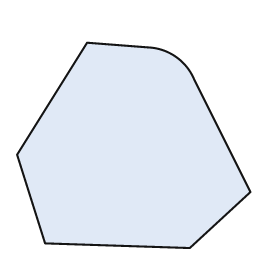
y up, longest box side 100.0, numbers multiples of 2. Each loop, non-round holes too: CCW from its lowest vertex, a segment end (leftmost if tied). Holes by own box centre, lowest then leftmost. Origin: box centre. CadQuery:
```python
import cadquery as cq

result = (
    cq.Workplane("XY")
    .moveTo(24.0, -44.0)
    .lineTo(50.0, -20.0)
    .lineTo(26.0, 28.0)
    .threePointArc((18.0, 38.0), (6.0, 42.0))
    .lineTo(-20.0, 44.0)
    .lineTo(-50.0, -4.0)
    .lineTo(-38.0, -42.0)
    .close()
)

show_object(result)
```